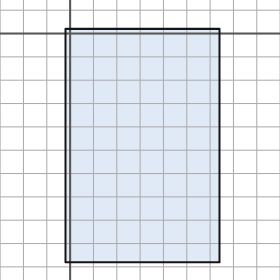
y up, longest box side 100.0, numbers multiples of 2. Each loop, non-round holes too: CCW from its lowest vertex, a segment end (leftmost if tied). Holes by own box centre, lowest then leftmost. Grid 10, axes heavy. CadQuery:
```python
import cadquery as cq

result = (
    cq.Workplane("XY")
    .moveTo(-2.0, -98.0)
    .lineTo(64.0, -98.0)
    .lineTo(64.0, 2.0)
    .lineTo(-2.0, 2.0)
    .close()
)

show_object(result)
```